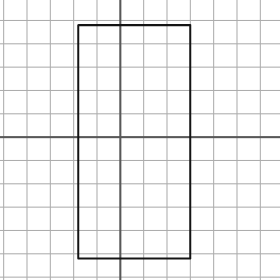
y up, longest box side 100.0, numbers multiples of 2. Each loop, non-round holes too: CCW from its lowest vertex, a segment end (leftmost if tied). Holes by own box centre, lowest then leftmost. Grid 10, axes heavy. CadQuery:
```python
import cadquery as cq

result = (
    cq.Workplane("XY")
    .moveTo(-18.0, -52.0)
    .lineTo(30.0, -52.0)
    .lineTo(30.0, 48.0)
    .lineTo(-18.0, 48.0)
    .close()
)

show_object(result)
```